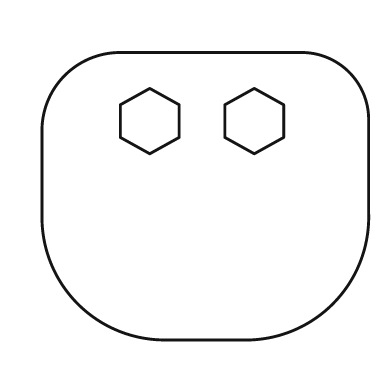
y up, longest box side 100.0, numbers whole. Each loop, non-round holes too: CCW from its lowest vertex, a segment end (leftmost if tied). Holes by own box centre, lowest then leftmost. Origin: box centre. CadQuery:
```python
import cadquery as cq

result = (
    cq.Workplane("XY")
    .moveTo(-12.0, -44.0)
    .lineTo(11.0, -44.0)
    .threePointArc((39.0, -33.0), (50.0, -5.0))
    .lineTo(50.0, 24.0)
    .threePointArc((44.0, 38.0), (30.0, 44.0))
    .lineTo(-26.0, 44.0)
    .threePointArc((-43.0, 37.0), (-50.0, 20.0))
    .lineTo(-50.0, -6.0)
    .threePointArc((-39.0, -33.0), (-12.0, -44.0))
    .close()
    .moveTo(-17.0, 13.0)
    .lineTo(-8.0, 18.0)
    .lineTo(-8.0, 28.0)
    .lineTo(-17.0, 33.0)
    .lineTo(-26.0, 28.0)
    .lineTo(-26.0, 18.0)
    .close()
    .moveTo(15.0, 13.0)
    .lineTo(24.0, 18.0)
    .lineTo(24.0, 28.0)
    .lineTo(15.0, 33.0)
    .lineTo(6.0, 28.0)
    .lineTo(6.0, 18.0)
    .close()
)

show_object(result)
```